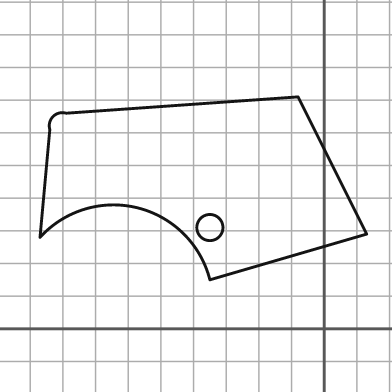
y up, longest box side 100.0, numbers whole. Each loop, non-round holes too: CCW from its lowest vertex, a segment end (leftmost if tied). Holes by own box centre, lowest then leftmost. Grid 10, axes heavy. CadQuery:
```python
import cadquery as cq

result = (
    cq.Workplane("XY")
    .moveTo(-35.0, 15.0)
    .lineTo(13.0, 29.0)
    .lineTo(-8.0, 71.0)
    .lineTo(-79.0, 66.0)
    .threePointArc((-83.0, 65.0), (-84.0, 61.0))
    .lineTo(-87.0, 28.0)
    .threePointArc((-57.0, 37.0), (-35.0, 15.0))
    .close()
    .moveTo(-35.0, 31.0)
    .circle(4.0)
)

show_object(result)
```